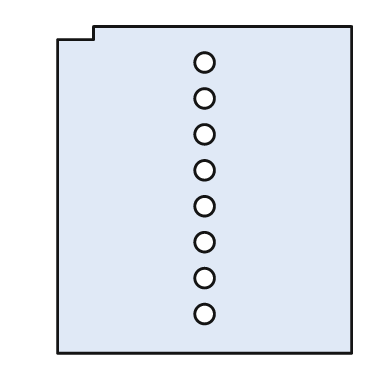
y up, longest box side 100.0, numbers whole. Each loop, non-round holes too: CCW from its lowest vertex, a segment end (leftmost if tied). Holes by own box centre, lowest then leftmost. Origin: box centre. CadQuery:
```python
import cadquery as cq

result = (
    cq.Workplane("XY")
    .moveTo(-45.0, -50.0)
    .lineTo(45.0, -50.0)
    .lineTo(45.0, 50.0)
    .lineTo(-34.0, 50.0)
    .lineTo(-34.0, 46.0)
    .lineTo(-45.0, 46.0)
    .close()
    .moveTo(0.0, -38.0)
    .circle(3.0)
    .moveTo(0.0, -27.0)
    .circle(3.0)
    .moveTo(0.0, -16.0)
    .circle(3.0)
    .moveTo(0.0, -5.0)
    .circle(3.0)
    .moveTo(0.0, 6.0)
    .circle(3.0)
    .moveTo(0.0, 17.0)
    .circle(3.0)
    .moveTo(0.0, 28.0)
    .circle(3.0)
    .moveTo(0.0, 39.0)
    .circle(3.0)
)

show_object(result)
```